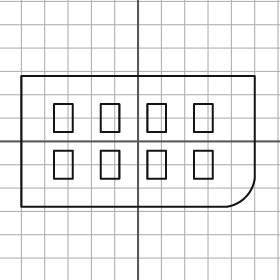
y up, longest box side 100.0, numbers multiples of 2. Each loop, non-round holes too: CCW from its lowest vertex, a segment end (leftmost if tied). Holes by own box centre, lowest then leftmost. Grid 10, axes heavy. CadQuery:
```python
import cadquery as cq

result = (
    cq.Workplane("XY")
    .moveTo(-50.0, -28.0)
    .lineTo(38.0, -28.0)
    .threePointArc((46.0, -24.0), (50.0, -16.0))
    .lineTo(50.0, 28.0)
    .lineTo(-50.0, 28.0)
    .close()
    .moveTo(-36.0, -16.0)
    .lineTo(-28.0, -16.0)
    .lineTo(-28.0, -4.0)
    .lineTo(-36.0, -4.0)
    .close()
    .moveTo(-16.0, -16.0)
    .lineTo(-8.0, -16.0)
    .lineTo(-8.0, -4.0)
    .lineTo(-16.0, -4.0)
    .close()
    .moveTo(4.0, -16.0)
    .lineTo(12.0, -16.0)
    .lineTo(12.0, -4.0)
    .lineTo(4.0, -4.0)
    .close()
    .moveTo(24.0, -16.0)
    .lineTo(32.0, -16.0)
    .lineTo(32.0, -4.0)
    .lineTo(24.0, -4.0)
    .close()
    .moveTo(-36.0, 4.0)
    .lineTo(-28.0, 4.0)
    .lineTo(-28.0, 16.0)
    .lineTo(-36.0, 16.0)
    .close()
    .moveTo(-16.0, 4.0)
    .lineTo(-8.0, 4.0)
    .lineTo(-8.0, 16.0)
    .lineTo(-16.0, 16.0)
    .close()
    .moveTo(4.0, 4.0)
    .lineTo(12.0, 4.0)
    .lineTo(12.0, 16.0)
    .lineTo(4.0, 16.0)
    .close()
    .moveTo(24.0, 4.0)
    .lineTo(32.0, 4.0)
    .lineTo(32.0, 16.0)
    .lineTo(24.0, 16.0)
    .close()
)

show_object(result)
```